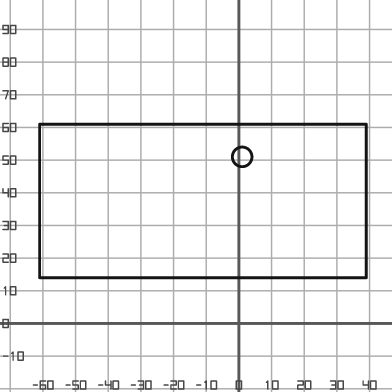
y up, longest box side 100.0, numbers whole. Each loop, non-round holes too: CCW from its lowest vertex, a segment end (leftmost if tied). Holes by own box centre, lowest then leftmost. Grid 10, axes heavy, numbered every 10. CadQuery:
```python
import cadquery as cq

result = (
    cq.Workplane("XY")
    .moveTo(-61.0, 14.0)
    .lineTo(39.0, 14.0)
    .lineTo(39.0, 61.0)
    .lineTo(-61.0, 61.0)
    .close()
    .moveTo(1.0, 51.0)
    .circle(3.0)
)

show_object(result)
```